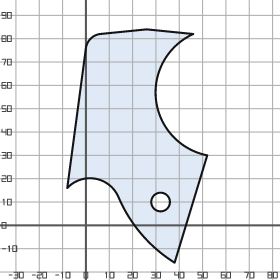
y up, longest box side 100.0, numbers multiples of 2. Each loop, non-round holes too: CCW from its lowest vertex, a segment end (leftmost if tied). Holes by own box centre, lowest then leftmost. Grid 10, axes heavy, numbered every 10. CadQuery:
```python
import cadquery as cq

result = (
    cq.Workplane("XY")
    .moveTo(38.0, -16.0)
    .lineTo(52.0, 30.0)
    .threePointArc((30.0, 54.0), (46.0, 82.0))
    .lineTo(26.0, 84.0)
    .lineTo(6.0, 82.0)
    .threePointArc((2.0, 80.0), (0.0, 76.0))
    .lineTo(-8.0, 16.0)
    .threePointArc((4.0, 20.0), (14.0, 12.0))
    .threePointArc((24.0, -4.0), (38.0, -16.0))
    .close()
    .moveTo(32.0, 10.0)
    .circle(4.0)
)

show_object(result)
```